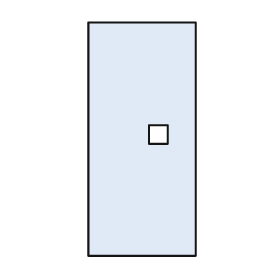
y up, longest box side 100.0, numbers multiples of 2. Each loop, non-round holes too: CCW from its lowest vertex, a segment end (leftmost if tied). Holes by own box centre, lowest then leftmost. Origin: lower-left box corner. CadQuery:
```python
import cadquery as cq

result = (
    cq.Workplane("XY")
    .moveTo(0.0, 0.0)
    .lineTo(46.0, 0.0)
    .lineTo(46.0, 100.0)
    .lineTo(0.0, 100.0)
    .close()
    .moveTo(26.0, 48.0)
    .lineTo(34.0, 48.0)
    .lineTo(34.0, 56.0)
    .lineTo(26.0, 56.0)
    .close()
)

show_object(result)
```